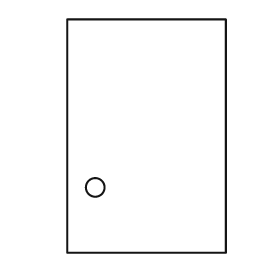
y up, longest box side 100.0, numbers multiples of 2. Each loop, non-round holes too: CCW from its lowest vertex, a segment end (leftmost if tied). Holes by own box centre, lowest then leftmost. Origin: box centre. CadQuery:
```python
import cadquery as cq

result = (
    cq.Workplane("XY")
    .moveTo(-34.0, -50.0)
    .lineTo(34.0, -50.0)
    .lineTo(34.0, 50.0)
    .lineTo(-34.0, 50.0)
    .close()
    .moveTo(-22.0, -22.0)
    .circle(4.0)
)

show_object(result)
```